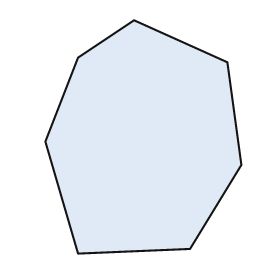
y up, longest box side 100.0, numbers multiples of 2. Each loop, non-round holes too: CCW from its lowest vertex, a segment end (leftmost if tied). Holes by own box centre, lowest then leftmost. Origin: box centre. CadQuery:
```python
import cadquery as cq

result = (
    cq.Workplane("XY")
    .moveTo(-28.0, -50.0)
    .lineTo(20.0, -48.0)
    .lineTo(42.0, -12.0)
    .lineTo(36.0, 32.0)
    .lineTo(-4.0, 50.0)
    .lineTo(-28.0, 34.0)
    .lineTo(-42.0, -2.0)
    .close()
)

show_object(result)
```